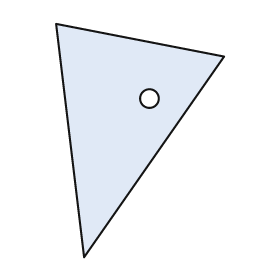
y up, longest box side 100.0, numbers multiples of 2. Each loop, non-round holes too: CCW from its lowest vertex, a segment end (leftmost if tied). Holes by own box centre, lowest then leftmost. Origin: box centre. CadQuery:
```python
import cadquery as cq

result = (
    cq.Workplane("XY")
    .moveTo(-24.0, -50.0)
    .lineTo(36.0, 36.0)
    .lineTo(-36.0, 50.0)
    .close()
    .moveTo(4.0, 18.0)
    .circle(4.0)
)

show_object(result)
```